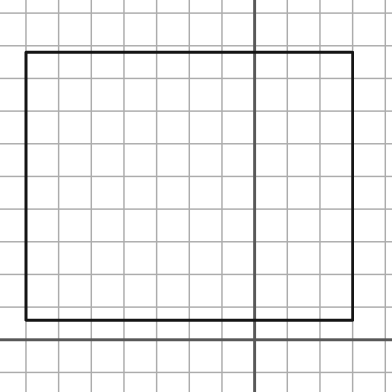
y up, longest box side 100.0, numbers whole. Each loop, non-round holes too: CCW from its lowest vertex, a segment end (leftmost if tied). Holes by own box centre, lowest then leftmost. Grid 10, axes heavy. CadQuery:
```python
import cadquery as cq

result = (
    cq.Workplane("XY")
    .moveTo(-70.0, 6.0)
    .lineTo(30.0, 6.0)
    .lineTo(30.0, 88.0)
    .lineTo(-70.0, 88.0)
    .close()
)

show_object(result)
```